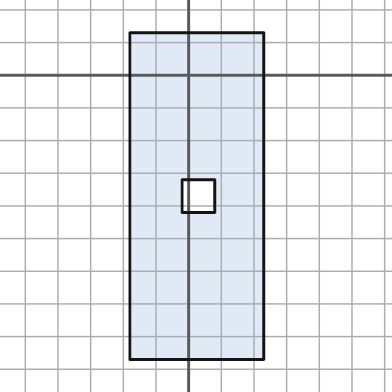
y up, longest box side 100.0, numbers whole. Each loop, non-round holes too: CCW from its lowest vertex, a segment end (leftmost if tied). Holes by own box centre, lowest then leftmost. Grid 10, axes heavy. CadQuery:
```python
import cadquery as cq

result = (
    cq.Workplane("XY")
    .moveTo(-18.0, -87.0)
    .lineTo(23.0, -87.0)
    .lineTo(23.0, 13.0)
    .lineTo(-18.0, 13.0)
    .close()
    .moveTo(-2.0, -42.0)
    .lineTo(8.0, -42.0)
    .lineTo(8.0, -32.0)
    .lineTo(-2.0, -32.0)
    .close()
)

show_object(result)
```